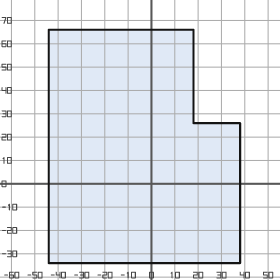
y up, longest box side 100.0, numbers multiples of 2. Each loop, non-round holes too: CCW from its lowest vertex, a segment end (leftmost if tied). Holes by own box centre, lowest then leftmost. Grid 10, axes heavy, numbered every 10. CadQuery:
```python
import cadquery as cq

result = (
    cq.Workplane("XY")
    .moveTo(-44.0, -34.0)
    .lineTo(38.0, -34.0)
    .lineTo(38.0, 26.0)
    .lineTo(18.0, 26.0)
    .lineTo(18.0, 66.0)
    .lineTo(-44.0, 66.0)
    .close()
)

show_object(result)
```